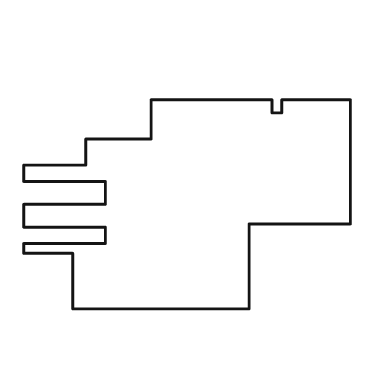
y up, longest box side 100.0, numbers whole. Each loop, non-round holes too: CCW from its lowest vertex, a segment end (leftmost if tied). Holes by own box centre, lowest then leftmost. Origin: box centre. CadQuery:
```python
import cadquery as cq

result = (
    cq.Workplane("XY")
    .moveTo(-35.0, -32.0)
    .lineTo(19.0, -32.0)
    .lineTo(19.0, -6.0)
    .lineTo(50.0, -6.0)
    .lineTo(50.0, 32.0)
    .lineTo(29.0, 32.0)
    .lineTo(29.0, 28.0)
    .lineTo(26.0, 28.0)
    .lineTo(26.0, 32.0)
    .lineTo(-11.0, 32.0)
    .lineTo(-11.0, 20.0)
    .lineTo(-31.0, 20.0)
    .lineTo(-31.0, 12.0)
    .lineTo(-50.0, 12.0)
    .lineTo(-50.0, 7.0)
    .lineTo(-25.0, 7.0)
    .lineTo(-25.0, 0.0)
    .lineTo(-50.0, 0.0)
    .lineTo(-50.0, -7.0)
    .lineTo(-25.0, -7.0)
    .lineTo(-25.0, -12.0)
    .lineTo(-50.0, -12.0)
    .lineTo(-50.0, -15.0)
    .lineTo(-35.0, -15.0)
    .close()
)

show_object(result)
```